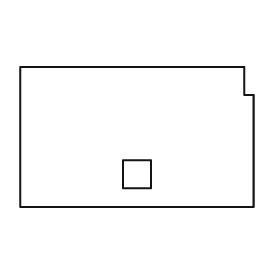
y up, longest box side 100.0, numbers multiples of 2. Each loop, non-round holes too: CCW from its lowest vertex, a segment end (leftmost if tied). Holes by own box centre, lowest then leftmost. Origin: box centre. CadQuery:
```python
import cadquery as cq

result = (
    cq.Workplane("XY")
    .moveTo(-50.0, -30.0)
    .lineTo(50.0, -30.0)
    .lineTo(50.0, 18.0)
    .lineTo(46.0, 18.0)
    .lineTo(46.0, 30.0)
    .lineTo(-50.0, 30.0)
    .close()
    .moveTo(-6.0, -22.0)
    .lineTo(6.0, -22.0)
    .lineTo(6.0, -10.0)
    .lineTo(-6.0, -10.0)
    .close()
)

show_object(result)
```